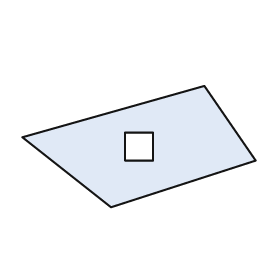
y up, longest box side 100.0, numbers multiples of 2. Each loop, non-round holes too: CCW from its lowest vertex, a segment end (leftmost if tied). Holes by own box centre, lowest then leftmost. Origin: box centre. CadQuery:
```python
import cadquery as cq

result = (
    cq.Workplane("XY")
    .moveTo(-12.0, -26.0)
    .lineTo(50.0, -6.0)
    .lineTo(28.0, 26.0)
    .lineTo(-50.0, 4.0)
    .close()
    .moveTo(-6.0, -6.0)
    .lineTo(6.0, -6.0)
    .lineTo(6.0, 6.0)
    .lineTo(-6.0, 6.0)
    .close()
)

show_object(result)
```